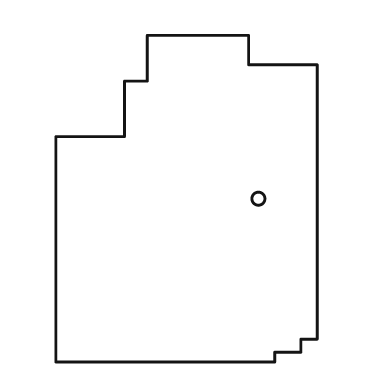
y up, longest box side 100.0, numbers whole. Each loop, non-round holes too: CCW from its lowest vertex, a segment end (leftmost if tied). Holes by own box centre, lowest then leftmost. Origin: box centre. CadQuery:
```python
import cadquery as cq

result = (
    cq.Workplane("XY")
    .moveTo(-40.0, -50.0)
    .lineTo(27.0, -50.0)
    .lineTo(27.0, -47.0)
    .lineTo(35.0, -47.0)
    .lineTo(35.0, -43.0)
    .lineTo(40.0, -43.0)
    .lineTo(40.0, 41.0)
    .lineTo(19.0, 41.0)
    .lineTo(19.0, 50.0)
    .lineTo(-12.0, 50.0)
    .lineTo(-12.0, 36.0)
    .lineTo(-19.0, 36.0)
    .lineTo(-19.0, 19.0)
    .lineTo(-40.0, 19.0)
    .close()
    .moveTo(22.0, 0.0)
    .circle(2.0)
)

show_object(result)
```